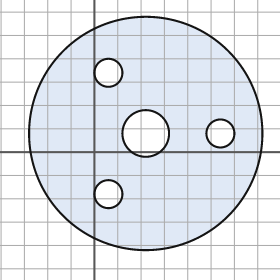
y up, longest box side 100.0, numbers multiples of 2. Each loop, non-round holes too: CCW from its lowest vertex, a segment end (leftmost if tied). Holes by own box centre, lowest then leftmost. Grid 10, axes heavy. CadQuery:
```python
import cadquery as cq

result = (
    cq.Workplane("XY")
    .moveTo(22.0, 8.0)
    .circle(50.0)
    .moveTo(6.0, -18.0)
    .circle(6.0)
    .moveTo(22.0, 8.0)
    .circle(10.0)
    .moveTo(54.0, 8.0)
    .circle(6.0)
    .moveTo(6.0, 34.0)
    .circle(6.0)
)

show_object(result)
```